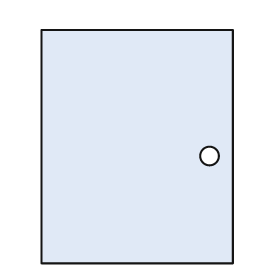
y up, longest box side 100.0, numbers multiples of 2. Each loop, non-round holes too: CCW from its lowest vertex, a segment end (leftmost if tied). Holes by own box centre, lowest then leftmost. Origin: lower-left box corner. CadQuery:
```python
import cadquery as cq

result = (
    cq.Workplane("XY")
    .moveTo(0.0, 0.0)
    .lineTo(82.0, 0.0)
    .lineTo(82.0, 100.0)
    .lineTo(0.0, 100.0)
    .close()
    .moveTo(72.0, 46.0)
    .circle(4.0)
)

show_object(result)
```